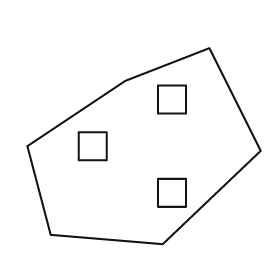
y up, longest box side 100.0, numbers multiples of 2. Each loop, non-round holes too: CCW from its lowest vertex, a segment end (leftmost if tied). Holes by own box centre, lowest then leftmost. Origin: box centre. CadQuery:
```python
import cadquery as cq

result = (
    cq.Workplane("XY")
    .moveTo(8.0, -42.0)
    .lineTo(50.0, -2.0)
    .lineTo(28.0, 42.0)
    .lineTo(-8.0, 28.0)
    .lineTo(-50.0, 0.0)
    .lineTo(-40.0, -38.0)
    .close()
    .moveTo(6.0, -26.0)
    .lineTo(18.0, -26.0)
    .lineTo(18.0, -14.0)
    .lineTo(6.0, -14.0)
    .close()
    .moveTo(-28.0, -6.0)
    .lineTo(-16.0, -6.0)
    .lineTo(-16.0, 6.0)
    .lineTo(-28.0, 6.0)
    .close()
    .moveTo(6.0, 14.0)
    .lineTo(18.0, 14.0)
    .lineTo(18.0, 26.0)
    .lineTo(6.0, 26.0)
    .close()
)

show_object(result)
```